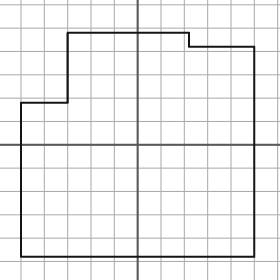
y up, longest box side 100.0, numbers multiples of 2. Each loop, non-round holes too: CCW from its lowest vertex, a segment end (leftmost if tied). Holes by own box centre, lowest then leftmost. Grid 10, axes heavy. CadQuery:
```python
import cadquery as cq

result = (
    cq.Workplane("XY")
    .moveTo(-50.0, -48.0)
    .lineTo(50.0, -48.0)
    .lineTo(50.0, 42.0)
    .lineTo(22.0, 42.0)
    .lineTo(22.0, 48.0)
    .lineTo(-30.0, 48.0)
    .lineTo(-30.0, 18.0)
    .lineTo(-50.0, 18.0)
    .close()
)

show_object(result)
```